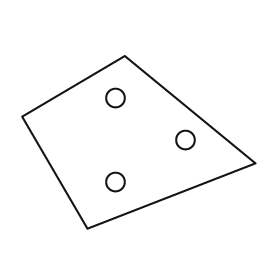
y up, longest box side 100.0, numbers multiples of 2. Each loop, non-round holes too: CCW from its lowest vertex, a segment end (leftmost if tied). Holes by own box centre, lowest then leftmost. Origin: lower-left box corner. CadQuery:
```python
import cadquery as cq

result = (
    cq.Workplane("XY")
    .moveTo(28.0, 0.0)
    .lineTo(100.0, 28.0)
    .lineTo(44.0, 74.0)
    .lineTo(0.0, 48.0)
    .close()
    .moveTo(40.0, 20.0)
    .circle(4.0)
    .moveTo(70.0, 38.0)
    .circle(4.0)
    .moveTo(40.0, 56.0)
    .circle(4.0)
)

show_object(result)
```